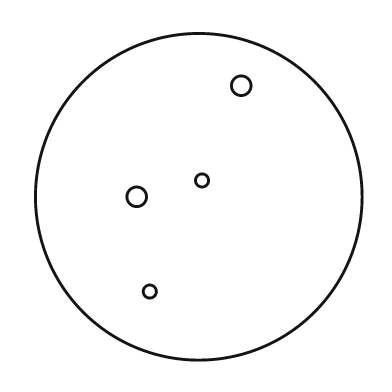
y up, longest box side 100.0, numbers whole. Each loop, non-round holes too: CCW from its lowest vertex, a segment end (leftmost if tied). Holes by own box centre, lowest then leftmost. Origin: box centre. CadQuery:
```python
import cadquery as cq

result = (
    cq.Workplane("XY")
    .moveTo(0.0, 0.0)
    .circle(50.0)
    .moveTo(-15.0, -29.0)
    .circle(2.0)
    .moveTo(-19.0, 0.0)
    .circle(3.0)
    .moveTo(1.0, 5.0)
    .circle(2.0)
    .moveTo(13.0, 34.0)
    .circle(3.0)
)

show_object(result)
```